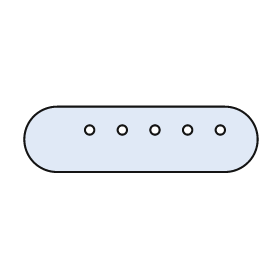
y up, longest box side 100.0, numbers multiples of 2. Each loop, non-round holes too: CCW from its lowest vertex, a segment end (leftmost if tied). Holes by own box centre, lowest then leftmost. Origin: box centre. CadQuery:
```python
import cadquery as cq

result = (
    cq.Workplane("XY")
    .moveTo(-36.0, -14.0)
    .lineTo(36.0, -14.0)
    .threePointArc((50.0, 0.0), (36.0, 14.0))
    .lineTo(-36.0, 14.0)
    .threePointArc((-50.0, 0.0), (-36.0, -14.0))
    .close()
    .moveTo(-22.0, 4.0)
    .circle(2.0)
    .moveTo(-8.0, 4.0)
    .circle(2.0)
    .moveTo(6.0, 4.0)
    .circle(2.0)
    .moveTo(20.0, 4.0)
    .circle(2.0)
    .moveTo(34.0, 4.0)
    .circle(2.0)
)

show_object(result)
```